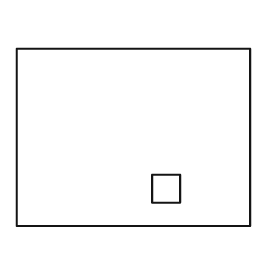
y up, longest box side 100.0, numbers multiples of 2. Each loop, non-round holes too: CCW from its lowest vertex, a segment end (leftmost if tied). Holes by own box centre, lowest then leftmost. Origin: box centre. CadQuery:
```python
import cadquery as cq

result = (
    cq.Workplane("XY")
    .moveTo(-50.0, -38.0)
    .lineTo(50.0, -38.0)
    .lineTo(50.0, 38.0)
    .lineTo(-50.0, 38.0)
    .close()
    .moveTo(8.0, -28.0)
    .lineTo(20.0, -28.0)
    .lineTo(20.0, -16.0)
    .lineTo(8.0, -16.0)
    .close()
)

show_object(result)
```